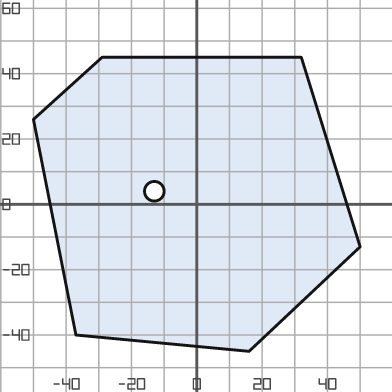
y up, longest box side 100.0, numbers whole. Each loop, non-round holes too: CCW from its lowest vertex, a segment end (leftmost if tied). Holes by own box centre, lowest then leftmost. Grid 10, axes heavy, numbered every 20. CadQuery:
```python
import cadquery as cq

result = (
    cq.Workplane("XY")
    .moveTo(16.0, -45.0)
    .lineTo(50.0, -13.0)
    .lineTo(32.0, 45.0)
    .lineTo(-29.0, 45.0)
    .lineTo(-50.0, 26.0)
    .lineTo(-37.0, -40.0)
    .close()
    .moveTo(-13.0, 4.0)
    .circle(3.0)
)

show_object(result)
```